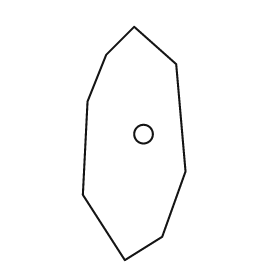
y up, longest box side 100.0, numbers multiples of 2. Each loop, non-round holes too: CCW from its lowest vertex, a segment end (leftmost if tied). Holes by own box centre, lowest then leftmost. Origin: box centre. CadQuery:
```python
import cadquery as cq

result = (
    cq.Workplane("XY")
    .moveTo(-4.0, -50.0)
    .lineTo(12.0, -40.0)
    .lineTo(22.0, -12.0)
    .lineTo(18.0, 34.0)
    .lineTo(0.0, 50.0)
    .lineTo(-12.0, 38.0)
    .lineTo(-20.0, 18.0)
    .lineTo(-22.0, -22.0)
    .close()
    .moveTo(4.0, 4.0)
    .circle(4.0)
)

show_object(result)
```